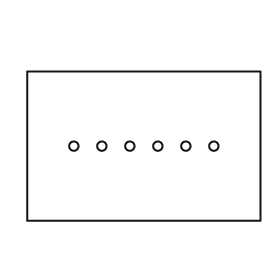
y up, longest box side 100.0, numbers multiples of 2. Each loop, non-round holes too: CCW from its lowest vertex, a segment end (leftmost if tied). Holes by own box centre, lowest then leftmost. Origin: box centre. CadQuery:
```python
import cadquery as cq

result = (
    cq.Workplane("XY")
    .moveTo(-50.0, -32.0)
    .lineTo(50.0, -32.0)
    .lineTo(50.0, 32.0)
    .lineTo(-50.0, 32.0)
    .close()
    .moveTo(-30.0, 0.0)
    .circle(2.0)
    .moveTo(-18.0, 0.0)
    .circle(2.0)
    .moveTo(-6.0, 0.0)
    .circle(2.0)
    .moveTo(6.0, 0.0)
    .circle(2.0)
    .moveTo(18.0, 0.0)
    .circle(2.0)
    .moveTo(30.0, 0.0)
    .circle(2.0)
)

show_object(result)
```